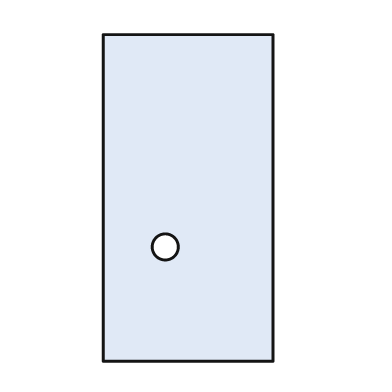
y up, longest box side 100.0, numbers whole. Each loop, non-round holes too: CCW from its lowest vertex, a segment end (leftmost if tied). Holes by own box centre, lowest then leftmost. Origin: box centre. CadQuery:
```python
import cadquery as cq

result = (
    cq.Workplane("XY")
    .moveTo(-26.0, -50.0)
    .lineTo(26.0, -50.0)
    .lineTo(26.0, 50.0)
    .lineTo(-26.0, 50.0)
    .close()
    .moveTo(-7.0, -15.0)
    .circle(4.0)
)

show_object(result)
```